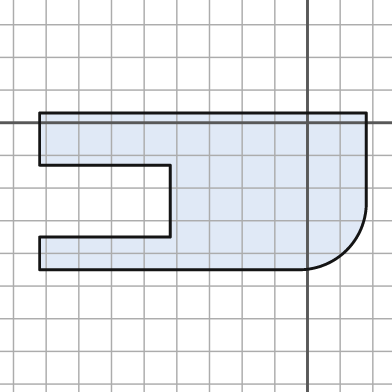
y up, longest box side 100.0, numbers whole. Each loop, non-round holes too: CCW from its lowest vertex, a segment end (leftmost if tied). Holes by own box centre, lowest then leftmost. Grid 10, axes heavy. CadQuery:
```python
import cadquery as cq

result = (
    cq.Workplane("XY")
    .moveTo(-82.0, -45.0)
    .lineTo(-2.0, -45.0)
    .threePointArc((12.0, -39.0), (18.0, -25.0))
    .lineTo(18.0, 3.0)
    .lineTo(-82.0, 3.0)
    .lineTo(-82.0, -13.0)
    .lineTo(-42.0, -13.0)
    .lineTo(-42.0, -35.0)
    .lineTo(-82.0, -35.0)
    .close()
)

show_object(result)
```